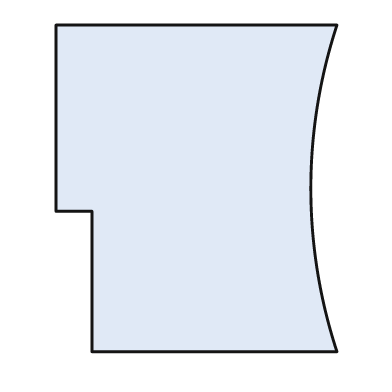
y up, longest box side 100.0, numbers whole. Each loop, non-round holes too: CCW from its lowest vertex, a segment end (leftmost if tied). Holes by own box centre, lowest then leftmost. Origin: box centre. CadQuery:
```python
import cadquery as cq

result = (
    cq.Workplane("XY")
    .moveTo(-32.0, -50.0)
    .lineTo(43.0, -50.0)
    .threePointArc((35.0, 0.0), (43.0, 50.0))
    .lineTo(-43.0, 50.0)
    .lineTo(-43.0, -7.0)
    .lineTo(-32.0, -7.0)
    .close()
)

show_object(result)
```